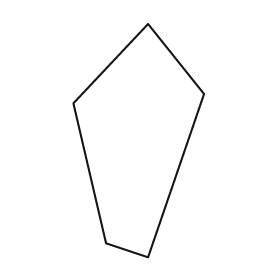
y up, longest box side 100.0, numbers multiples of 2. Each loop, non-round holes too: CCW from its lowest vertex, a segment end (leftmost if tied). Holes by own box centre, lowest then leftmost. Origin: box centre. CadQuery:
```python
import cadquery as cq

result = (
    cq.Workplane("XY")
    .moveTo(4.0, -50.0)
    .lineTo(28.0, 20.0)
    .lineTo(4.0, 50.0)
    .lineTo(-28.0, 16.0)
    .lineTo(-14.0, -44.0)
    .close()
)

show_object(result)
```